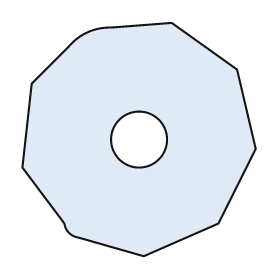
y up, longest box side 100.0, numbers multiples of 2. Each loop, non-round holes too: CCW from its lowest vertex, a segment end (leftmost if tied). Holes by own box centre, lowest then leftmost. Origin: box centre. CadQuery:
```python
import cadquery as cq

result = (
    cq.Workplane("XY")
    .moveTo(2.0, -50.0)
    .lineTo(34.0, -36.0)
    .lineTo(50.0, -4.0)
    .lineTo(42.0, 30.0)
    .lineTo(14.0, 50.0)
    .lineTo(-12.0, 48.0)
    .threePointArc((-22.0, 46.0), (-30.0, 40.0))
    .lineTo(-46.0, 24.0)
    .lineTo(-50.0, -12.0)
    .lineTo(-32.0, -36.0)
    .threePointArc((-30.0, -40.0), (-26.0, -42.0))
    .close()
    .moveTo(0.0, 0.0)
    .circle(12.0)
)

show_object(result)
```